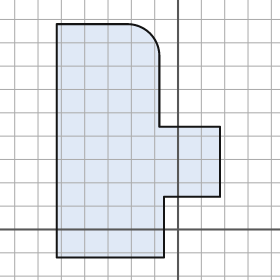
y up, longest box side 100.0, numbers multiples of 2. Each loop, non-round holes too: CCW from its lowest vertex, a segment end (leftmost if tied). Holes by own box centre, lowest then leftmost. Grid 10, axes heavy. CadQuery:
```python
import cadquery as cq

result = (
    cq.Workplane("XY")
    .moveTo(-52.0, -12.0)
    .lineTo(-6.0, -12.0)
    .lineTo(-6.0, 14.0)
    .lineTo(18.0, 14.0)
    .lineTo(18.0, 44.0)
    .lineTo(-8.0, 44.0)
    .lineTo(-8.0, 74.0)
    .threePointArc((-12.0, 84.0), (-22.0, 88.0))
    .lineTo(-52.0, 88.0)
    .close()
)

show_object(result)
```